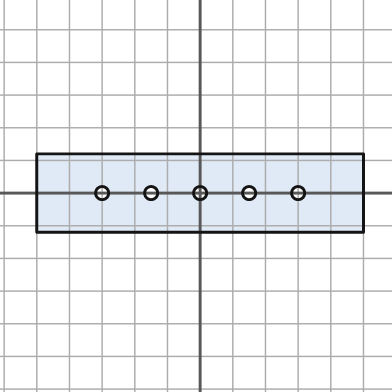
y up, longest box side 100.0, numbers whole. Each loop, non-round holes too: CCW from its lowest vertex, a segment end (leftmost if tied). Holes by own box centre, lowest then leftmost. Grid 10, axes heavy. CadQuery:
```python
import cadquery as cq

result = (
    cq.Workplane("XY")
    .moveTo(-50.0, -12.0)
    .lineTo(50.0, -12.0)
    .lineTo(50.0, 12.0)
    .lineTo(-50.0, 12.0)
    .close()
    .moveTo(-30.0, 0.0)
    .circle(2.0)
    .moveTo(-15.0, 0.0)
    .circle(2.0)
    .moveTo(0.0, 0.0)
    .circle(2.0)
    .moveTo(15.0, 0.0)
    .circle(2.0)
    .moveTo(30.0, 0.0)
    .circle(2.0)
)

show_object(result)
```